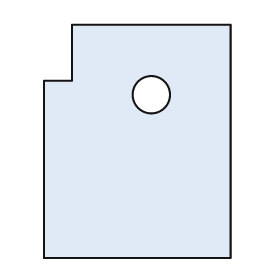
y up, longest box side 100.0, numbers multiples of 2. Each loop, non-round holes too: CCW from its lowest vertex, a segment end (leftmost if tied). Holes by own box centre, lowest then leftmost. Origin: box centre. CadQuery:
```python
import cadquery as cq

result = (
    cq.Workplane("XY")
    .moveTo(-40.0, -50.0)
    .lineTo(40.0, -50.0)
    .lineTo(40.0, 50.0)
    .lineTo(-28.0, 50.0)
    .lineTo(-28.0, 26.0)
    .lineTo(-40.0, 26.0)
    .close()
    .moveTo(6.0, 20.0)
    .circle(8.0)
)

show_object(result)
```